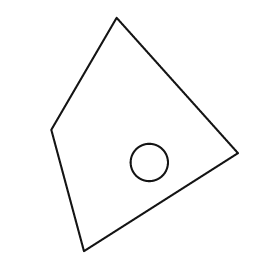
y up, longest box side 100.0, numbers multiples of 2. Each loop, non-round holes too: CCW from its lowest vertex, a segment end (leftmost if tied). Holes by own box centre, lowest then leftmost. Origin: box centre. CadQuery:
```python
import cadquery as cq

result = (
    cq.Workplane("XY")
    .moveTo(-26.0, -50.0)
    .lineTo(40.0, -8.0)
    .lineTo(-12.0, 50.0)
    .lineTo(-40.0, 2.0)
    .close()
    .moveTo(2.0, -12.0)
    .circle(8.0)
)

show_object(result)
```